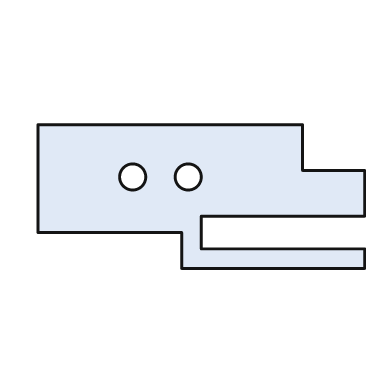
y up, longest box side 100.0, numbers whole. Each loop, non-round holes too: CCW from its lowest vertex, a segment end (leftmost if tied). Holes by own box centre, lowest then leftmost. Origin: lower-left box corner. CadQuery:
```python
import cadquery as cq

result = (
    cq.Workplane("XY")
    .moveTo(44.0, 0.0)
    .lineTo(100.0, 0.0)
    .lineTo(100.0, 6.0)
    .lineTo(50.0, 6.0)
    .lineTo(50.0, 16.0)
    .lineTo(100.0, 16.0)
    .lineTo(100.0, 30.0)
    .lineTo(81.0, 30.0)
    .lineTo(81.0, 44.0)
    .lineTo(0.0, 44.0)
    .lineTo(0.0, 11.0)
    .lineTo(44.0, 11.0)
    .close()
    .moveTo(29.0, 28.0)
    .circle(4.0)
    .moveTo(46.0, 28.0)
    .circle(4.0)
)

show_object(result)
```